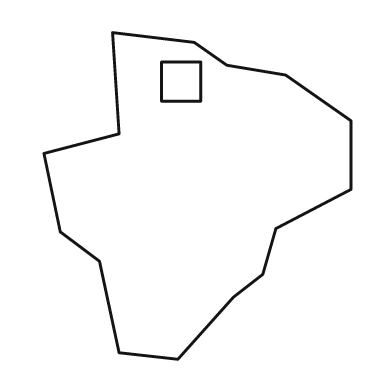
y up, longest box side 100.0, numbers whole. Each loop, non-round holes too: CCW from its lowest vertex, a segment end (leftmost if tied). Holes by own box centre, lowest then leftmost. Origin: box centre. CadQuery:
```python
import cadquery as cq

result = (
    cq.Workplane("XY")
    .moveTo(-6.0, -50.0)
    .lineTo(11.0, -31.0)
    .lineTo(20.0, -24.0)
    .lineTo(24.0, -10.0)
    .lineTo(47.0, 2.0)
    .lineTo(47.0, 23.0)
    .lineTo(27.0, 37.0)
    .lineTo(9.0, 40.0)
    .lineTo(-1.0, 47.0)
    .lineTo(-26.0, 50.0)
    .lineTo(-24.0, 19.0)
    .lineTo(-47.0, 13.0)
    .lineTo(-42.0, -11.0)
    .lineTo(-30.0, -20.0)
    .lineTo(-24.0, -48.0)
    .close()
    .moveTo(-11.0, 29.0)
    .lineTo(1.0, 29.0)
    .lineTo(1.0, 41.0)
    .lineTo(-11.0, 41.0)
    .close()
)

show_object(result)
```